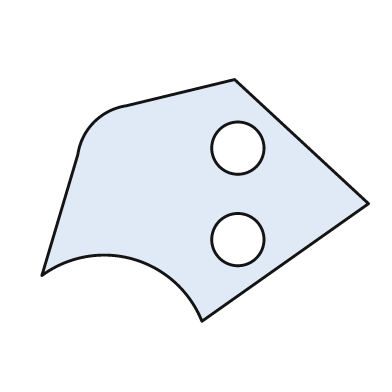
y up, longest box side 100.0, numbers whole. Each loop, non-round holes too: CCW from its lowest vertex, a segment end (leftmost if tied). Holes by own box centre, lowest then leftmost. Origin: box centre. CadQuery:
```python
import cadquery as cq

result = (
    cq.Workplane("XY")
    .moveTo(-1.0, -37.0)
    .lineTo(50.0, -1.0)
    .lineTo(9.0, 37.0)
    .lineTo(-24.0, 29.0)
    .threePointArc((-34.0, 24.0), (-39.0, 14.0))
    .lineTo(-50.0, -23.0)
    .threePointArc((-22.0, -18.0), (-1.0, -37.0))
    .close()
    .moveTo(10.0, -12.0)
    .circle(8.0)
    .moveTo(10.0, 16.0)
    .circle(8.0)
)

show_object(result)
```